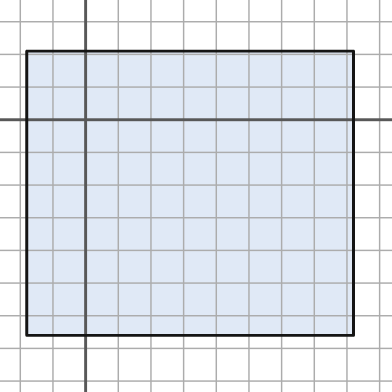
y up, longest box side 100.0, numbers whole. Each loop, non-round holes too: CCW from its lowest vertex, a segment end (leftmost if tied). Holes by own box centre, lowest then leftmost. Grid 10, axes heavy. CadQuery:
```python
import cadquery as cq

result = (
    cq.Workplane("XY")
    .moveTo(-18.0, -66.0)
    .lineTo(82.0, -66.0)
    .lineTo(82.0, 21.0)
    .lineTo(-18.0, 21.0)
    .close()
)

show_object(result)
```